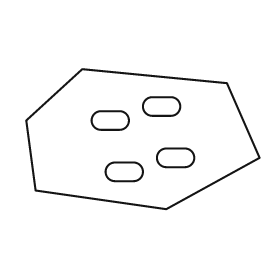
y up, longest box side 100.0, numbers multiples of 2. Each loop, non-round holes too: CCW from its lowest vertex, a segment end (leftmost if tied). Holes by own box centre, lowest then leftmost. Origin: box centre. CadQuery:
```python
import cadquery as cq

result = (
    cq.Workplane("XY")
    .moveTo(10.0, -30.0)
    .lineTo(50.0, -8.0)
    .lineTo(36.0, 24.0)
    .lineTo(-26.0, 30.0)
    .lineTo(-50.0, 8.0)
    .lineTo(-46.0, -22.0)
    .close()
    .moveTo(-12.0, -18.0)
    .lineTo(-4.0, -18.0)
    .threePointArc((0.0, -14.0), (-4.0, -10.0))
    .lineTo(-12.0, -10.0)
    .threePointArc((-16.0, -14.0), (-12.0, -18.0))
    .close()
    .moveTo(10.0, -12.0)
    .lineTo(18.0, -12.0)
    .threePointArc((22.0, -8.0), (18.0, -4.0))
    .lineTo(10.0, -4.0)
    .threePointArc((6.0, -8.0), (10.0, -12.0))
    .close()
    .moveTo(-18.0, 4.0)
    .lineTo(-10.0, 4.0)
    .threePointArc((-6.0, 8.0), (-10.0, 12.0))
    .lineTo(-18.0, 12.0)
    .threePointArc((-22.0, 8.0), (-18.0, 4.0))
    .close()
    .moveTo(4.0, 10.0)
    .lineTo(12.0, 10.0)
    .threePointArc((16.0, 14.0), (12.0, 18.0))
    .lineTo(4.0, 18.0)
    .threePointArc((0.0, 14.0), (4.0, 10.0))
    .close()
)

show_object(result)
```